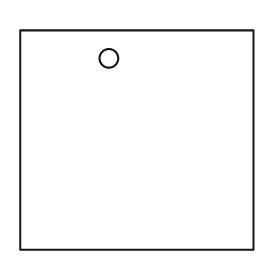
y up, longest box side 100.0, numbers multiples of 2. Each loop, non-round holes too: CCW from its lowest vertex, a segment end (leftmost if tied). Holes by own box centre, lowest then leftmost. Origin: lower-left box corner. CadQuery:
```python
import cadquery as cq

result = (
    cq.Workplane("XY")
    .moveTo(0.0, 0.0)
    .lineTo(100.0, 0.0)
    .lineTo(100.0, 94.0)
    .lineTo(0.0, 94.0)
    .close()
    .moveTo(38.0, 82.0)
    .circle(4.0)
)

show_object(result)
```